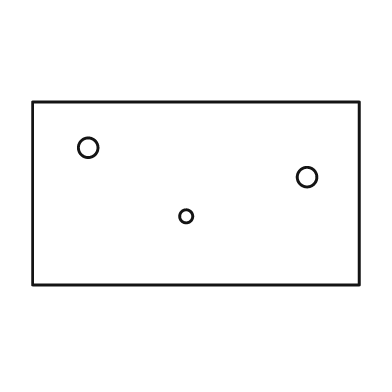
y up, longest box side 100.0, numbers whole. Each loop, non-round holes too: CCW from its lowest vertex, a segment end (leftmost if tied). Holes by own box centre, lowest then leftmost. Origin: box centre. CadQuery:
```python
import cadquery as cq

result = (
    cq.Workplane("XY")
    .moveTo(-50.0, -28.0)
    .lineTo(50.0, -28.0)
    .lineTo(50.0, 28.0)
    .lineTo(-50.0, 28.0)
    .close()
    .moveTo(-3.0, -7.0)
    .circle(2.0)
    .moveTo(34.0, 5.0)
    .circle(3.0)
    .moveTo(-33.0, 14.0)
    .circle(3.0)
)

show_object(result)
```